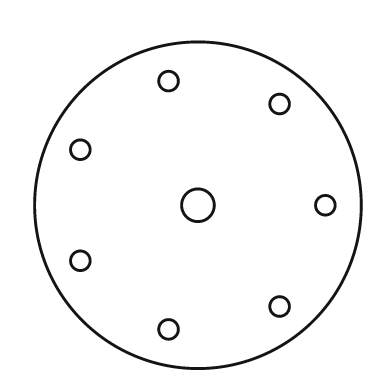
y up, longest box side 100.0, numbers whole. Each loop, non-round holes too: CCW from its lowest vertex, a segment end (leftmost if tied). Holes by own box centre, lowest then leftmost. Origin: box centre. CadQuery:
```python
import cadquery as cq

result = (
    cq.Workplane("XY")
    .moveTo(0.0, 0.0)
    .circle(50.0)
    .moveTo(-9.0, -38.0)
    .circle(3.0)
    .moveTo(25.0, -31.0)
    .circle(3.0)
    .moveTo(-36.0, -17.0)
    .circle(3.0)
    .moveTo(0.0, 0.0)
    .circle(5.0)
    .moveTo(39.0, 0.0)
    .circle(3.0)
    .moveTo(-36.0, 17.0)
    .circle(3.0)
    .moveTo(25.0, 31.0)
    .circle(3.0)
    .moveTo(-9.0, 38.0)
    .circle(3.0)
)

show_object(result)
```